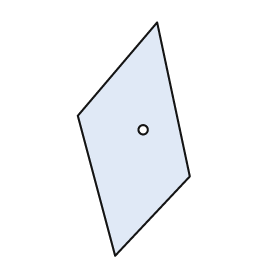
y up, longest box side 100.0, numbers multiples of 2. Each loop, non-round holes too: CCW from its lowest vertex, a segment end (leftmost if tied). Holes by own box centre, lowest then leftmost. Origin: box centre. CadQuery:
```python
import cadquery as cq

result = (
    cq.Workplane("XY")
    .moveTo(-8.0, -50.0)
    .lineTo(24.0, -16.0)
    .lineTo(10.0, 50.0)
    .lineTo(-24.0, 10.0)
    .close()
    .moveTo(4.0, 4.0)
    .circle(2.0)
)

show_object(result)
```